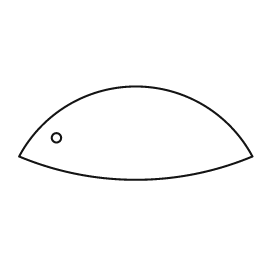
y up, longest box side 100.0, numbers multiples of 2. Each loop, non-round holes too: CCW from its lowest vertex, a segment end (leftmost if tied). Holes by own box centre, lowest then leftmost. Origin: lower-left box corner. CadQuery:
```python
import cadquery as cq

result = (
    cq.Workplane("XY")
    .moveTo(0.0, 10.0)
    .threePointArc((50.0, 0.0), (100.0, 10.0))
    .threePointArc((50.0, 40.0), (0.0, 10.0))
    .close()
    .moveTo(16.0, 18.0)
    .circle(2.0)
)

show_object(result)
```